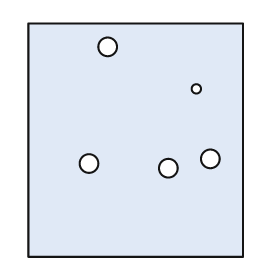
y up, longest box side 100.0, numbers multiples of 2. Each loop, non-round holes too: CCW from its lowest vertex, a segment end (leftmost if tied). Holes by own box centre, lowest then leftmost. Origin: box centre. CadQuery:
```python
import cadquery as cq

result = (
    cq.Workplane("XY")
    .moveTo(-46.0, -50.0)
    .lineTo(46.0, -50.0)
    .lineTo(46.0, 50.0)
    .lineTo(-46.0, 50.0)
    .close()
    .moveTo(14.0, -12.0)
    .circle(4.0)
    .moveTo(-20.0, -10.0)
    .circle(4.0)
    .moveTo(32.0, -8.0)
    .circle(4.0)
    .moveTo(26.0, 22.0)
    .circle(2.0)
    .moveTo(-12.0, 40.0)
    .circle(4.0)
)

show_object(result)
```